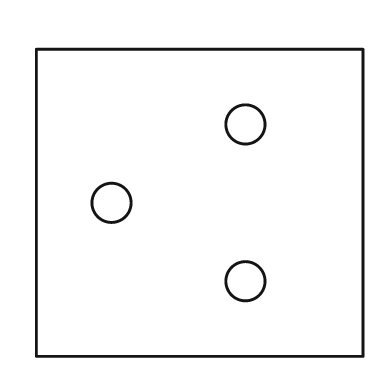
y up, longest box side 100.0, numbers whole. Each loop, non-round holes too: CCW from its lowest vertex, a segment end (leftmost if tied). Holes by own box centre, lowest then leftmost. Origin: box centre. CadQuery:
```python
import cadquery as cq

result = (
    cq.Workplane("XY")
    .moveTo(-50.0, -47.0)
    .lineTo(50.0, -47.0)
    .lineTo(50.0, 47.0)
    .lineTo(-50.0, 47.0)
    .close()
    .moveTo(14.0, -24.0)
    .circle(6.0)
    .moveTo(-27.0, 0.0)
    .circle(6.0)
    .moveTo(14.0, 24.0)
    .circle(6.0)
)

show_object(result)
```